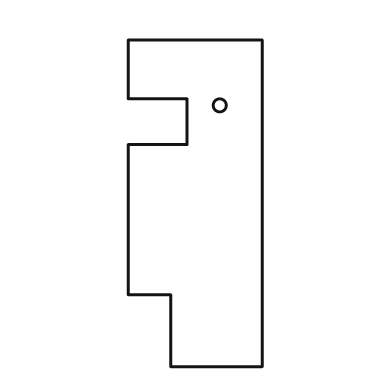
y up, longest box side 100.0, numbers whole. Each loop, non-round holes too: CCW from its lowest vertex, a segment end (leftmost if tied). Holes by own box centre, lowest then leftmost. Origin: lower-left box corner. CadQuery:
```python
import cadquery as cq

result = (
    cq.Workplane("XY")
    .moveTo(13.0, 0.0)
    .lineTo(41.0, 0.0)
    .lineTo(41.0, 100.0)
    .lineTo(0.0, 100.0)
    .lineTo(0.0, 82.0)
    .lineTo(18.0, 82.0)
    .lineTo(18.0, 68.0)
    .lineTo(0.0, 68.0)
    .lineTo(0.0, 22.0)
    .lineTo(13.0, 22.0)
    .close()
    .moveTo(28.0, 80.0)
    .circle(2.0)
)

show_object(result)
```